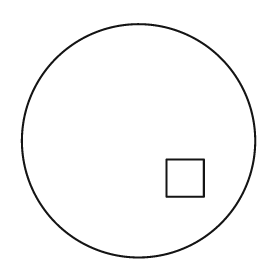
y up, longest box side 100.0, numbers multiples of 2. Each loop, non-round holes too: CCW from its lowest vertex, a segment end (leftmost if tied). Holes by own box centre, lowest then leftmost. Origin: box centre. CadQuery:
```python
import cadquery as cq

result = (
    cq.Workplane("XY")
    .moveTo(0.0, 0.0)
    .circle(50.0)
    .moveTo(12.0, -24.0)
    .lineTo(28.0, -24.0)
    .lineTo(28.0, -8.0)
    .lineTo(12.0, -8.0)
    .close()
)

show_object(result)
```